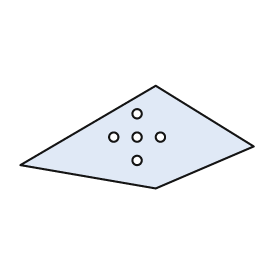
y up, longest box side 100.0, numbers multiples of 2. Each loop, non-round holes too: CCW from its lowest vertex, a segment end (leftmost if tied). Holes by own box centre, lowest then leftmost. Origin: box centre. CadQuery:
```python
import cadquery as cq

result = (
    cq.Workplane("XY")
    .moveTo(8.0, -22.0)
    .lineTo(50.0, -4.0)
    .lineTo(8.0, 22.0)
    .lineTo(-50.0, -12.0)
    .close()
    .moveTo(0.0, -10.0)
    .circle(2.0)
    .moveTo(-10.0, 0.0)
    .circle(2.0)
    .moveTo(0.0, 0.0)
    .circle(2.0)
    .moveTo(10.0, 0.0)
    .circle(2.0)
    .moveTo(0.0, 10.0)
    .circle(2.0)
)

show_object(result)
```